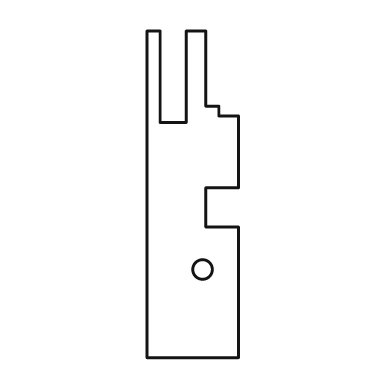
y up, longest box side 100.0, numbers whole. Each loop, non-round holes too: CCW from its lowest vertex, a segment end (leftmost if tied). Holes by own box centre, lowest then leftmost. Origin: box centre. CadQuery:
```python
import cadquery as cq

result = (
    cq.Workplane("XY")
    .moveTo(-14.0, -50.0)
    .lineTo(14.0, -50.0)
    .lineTo(14.0, -10.0)
    .lineTo(4.0, -10.0)
    .lineTo(4.0, 2.0)
    .lineTo(14.0, 2.0)
    .lineTo(14.0, 24.0)
    .lineTo(8.0, 24.0)
    .lineTo(8.0, 27.0)
    .lineTo(4.0, 27.0)
    .lineTo(4.0, 50.0)
    .lineTo(-2.0, 50.0)
    .lineTo(-2.0, 22.0)
    .lineTo(-10.0, 22.0)
    .lineTo(-10.0, 50.0)
    .lineTo(-14.0, 50.0)
    .close()
    .moveTo(3.0, -23.0)
    .circle(3.0)
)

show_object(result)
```